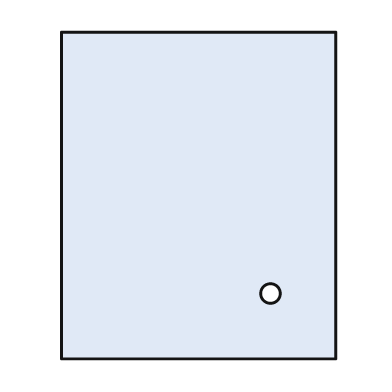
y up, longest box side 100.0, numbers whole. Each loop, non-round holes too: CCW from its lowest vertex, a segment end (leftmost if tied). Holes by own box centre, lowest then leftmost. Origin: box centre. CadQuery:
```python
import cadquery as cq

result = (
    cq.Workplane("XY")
    .moveTo(-42.0, -50.0)
    .lineTo(42.0, -50.0)
    .lineTo(42.0, 50.0)
    .lineTo(-42.0, 50.0)
    .close()
    .moveTo(22.0, -30.0)
    .circle(3.0)
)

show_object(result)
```